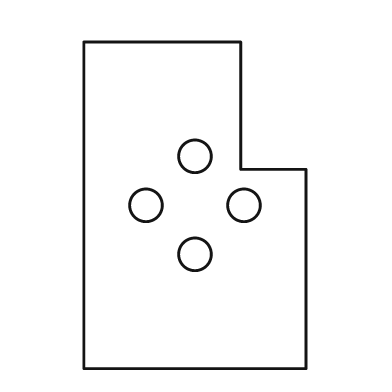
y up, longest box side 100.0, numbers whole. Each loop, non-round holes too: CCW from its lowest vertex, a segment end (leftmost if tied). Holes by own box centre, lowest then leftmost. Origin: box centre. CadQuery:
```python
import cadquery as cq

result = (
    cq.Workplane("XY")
    .moveTo(-34.0, -50.0)
    .lineTo(34.0, -50.0)
    .lineTo(34.0, 11.0)
    .lineTo(14.0, 11.0)
    .lineTo(14.0, 50.0)
    .lineTo(-34.0, 50.0)
    .close()
    .moveTo(0.0, -15.0)
    .circle(5.0)
    .moveTo(-15.0, 0.0)
    .circle(5.0)
    .moveTo(15.0, 0.0)
    .circle(5.0)
    .moveTo(0.0, 15.0)
    .circle(5.0)
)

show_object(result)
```